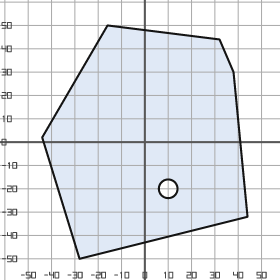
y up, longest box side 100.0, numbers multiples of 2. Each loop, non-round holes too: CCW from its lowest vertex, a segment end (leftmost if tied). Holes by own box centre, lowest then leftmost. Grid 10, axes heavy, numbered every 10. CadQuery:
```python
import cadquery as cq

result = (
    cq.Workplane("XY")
    .moveTo(-28.0, -50.0)
    .lineTo(44.0, -32.0)
    .lineTo(38.0, 30.0)
    .lineTo(32.0, 44.0)
    .lineTo(-16.0, 50.0)
    .lineTo(-44.0, 2.0)
    .close()
    .moveTo(10.0, -20.0)
    .circle(4.0)
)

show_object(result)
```